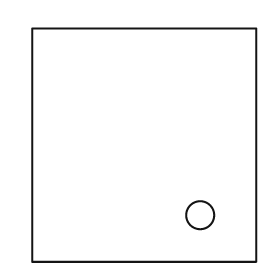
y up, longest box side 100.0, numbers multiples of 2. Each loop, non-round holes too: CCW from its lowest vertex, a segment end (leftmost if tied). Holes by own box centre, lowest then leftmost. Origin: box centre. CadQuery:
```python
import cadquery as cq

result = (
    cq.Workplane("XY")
    .moveTo(-48.0, -50.0)
    .lineTo(48.0, -50.0)
    .lineTo(48.0, 50.0)
    .lineTo(-48.0, 50.0)
    .close()
    .moveTo(24.0, -30.0)
    .circle(6.0)
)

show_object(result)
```